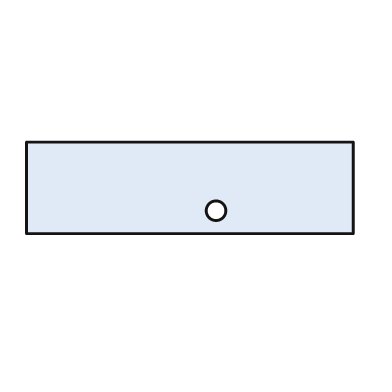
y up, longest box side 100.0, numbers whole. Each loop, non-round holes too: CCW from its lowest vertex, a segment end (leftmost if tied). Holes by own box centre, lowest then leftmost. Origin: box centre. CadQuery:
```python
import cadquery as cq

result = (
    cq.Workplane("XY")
    .moveTo(-50.0, -14.0)
    .lineTo(50.0, -14.0)
    .lineTo(50.0, 14.0)
    .lineTo(-50.0, 14.0)
    .close()
    .moveTo(8.0, -7.0)
    .circle(3.0)
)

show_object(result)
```